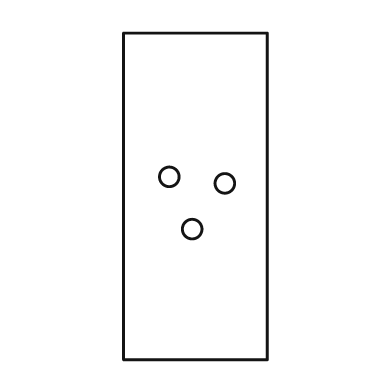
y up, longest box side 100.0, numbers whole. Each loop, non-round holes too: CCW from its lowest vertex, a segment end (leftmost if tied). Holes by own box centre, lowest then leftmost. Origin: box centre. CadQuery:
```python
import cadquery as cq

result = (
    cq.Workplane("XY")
    .moveTo(-22.0, -50.0)
    .lineTo(22.0, -50.0)
    .lineTo(22.0, 50.0)
    .lineTo(-22.0, 50.0)
    .close()
    .moveTo(-1.0, -10.0)
    .circle(3.0)
    .moveTo(9.0, 4.0)
    .circle(3.0)
    .moveTo(-8.0, 6.0)
    .circle(3.0)
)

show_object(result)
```